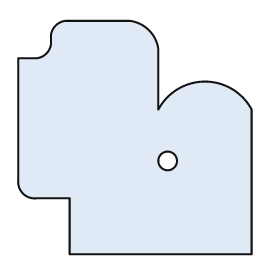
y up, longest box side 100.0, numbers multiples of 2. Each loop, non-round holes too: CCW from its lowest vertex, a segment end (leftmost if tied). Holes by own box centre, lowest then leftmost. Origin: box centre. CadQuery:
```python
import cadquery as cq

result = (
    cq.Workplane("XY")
    .moveTo(-28.0, -50.0)
    .lineTo(50.0, -50.0)
    .lineTo(50.0, 12.0)
    .threePointArc((30.0, 24.0), (10.0, 12.0))
    .lineTo(10.0, 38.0)
    .threePointArc((6.0, 46.0), (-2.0, 50.0))
    .lineTo(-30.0, 50.0)
    .threePointArc((-34.0, 48.0), (-36.0, 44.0))
    .lineTo(-36.0, 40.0)
    .threePointArc((-38.0, 36.0), (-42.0, 34.0))
    .lineTo(-50.0, 34.0)
    .lineTo(-50.0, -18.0)
    .threePointArc((-48.0, -24.0), (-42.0, -26.0))
    .lineTo(-28.0, -26.0)
    .close()
    .moveTo(14.0, -10.0)
    .circle(4.0)
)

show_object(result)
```